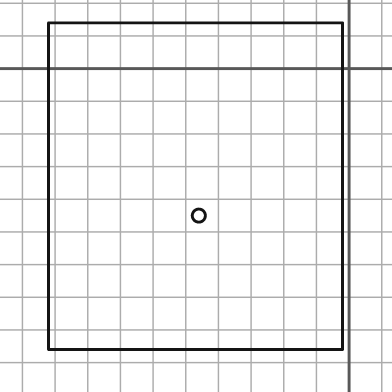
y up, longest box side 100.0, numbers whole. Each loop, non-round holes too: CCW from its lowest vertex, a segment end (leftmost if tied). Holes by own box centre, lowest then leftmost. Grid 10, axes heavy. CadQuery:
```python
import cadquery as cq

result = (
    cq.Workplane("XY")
    .moveTo(-92.0, -86.0)
    .lineTo(-2.0, -86.0)
    .lineTo(-2.0, 14.0)
    .lineTo(-92.0, 14.0)
    .close()
    .moveTo(-46.0, -45.0)
    .circle(2.0)
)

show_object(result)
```